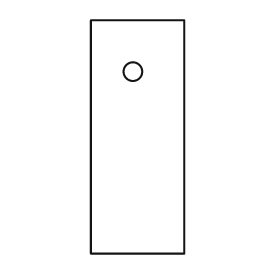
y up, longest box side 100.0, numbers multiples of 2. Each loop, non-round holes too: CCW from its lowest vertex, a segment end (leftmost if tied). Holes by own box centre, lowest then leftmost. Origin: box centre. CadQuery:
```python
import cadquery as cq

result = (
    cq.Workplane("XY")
    .moveTo(-20.0, -50.0)
    .lineTo(20.0, -50.0)
    .lineTo(20.0, 50.0)
    .lineTo(-20.0, 50.0)
    .close()
    .moveTo(-2.0, 28.0)
    .circle(4.0)
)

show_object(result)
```